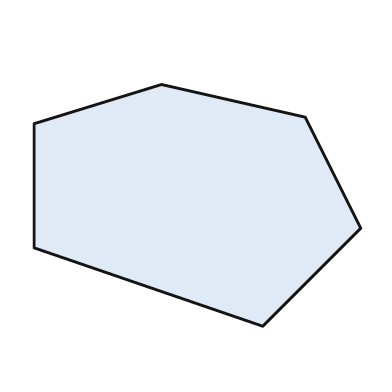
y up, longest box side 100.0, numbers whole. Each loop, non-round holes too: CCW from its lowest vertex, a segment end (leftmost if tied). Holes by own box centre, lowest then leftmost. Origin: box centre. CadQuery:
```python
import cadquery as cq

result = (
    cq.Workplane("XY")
    .moveTo(20.0, -37.0)
    .lineTo(50.0, -7.0)
    .lineTo(33.0, 27.0)
    .lineTo(-11.0, 37.0)
    .lineTo(-50.0, 25.0)
    .lineTo(-50.0, -13.0)
    .close()
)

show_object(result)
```